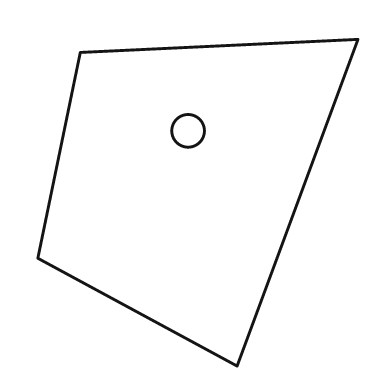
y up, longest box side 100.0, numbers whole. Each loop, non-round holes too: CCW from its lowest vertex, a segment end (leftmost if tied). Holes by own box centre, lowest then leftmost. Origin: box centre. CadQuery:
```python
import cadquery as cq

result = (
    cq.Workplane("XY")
    .moveTo(12.0, -50.0)
    .lineTo(49.0, 50.0)
    .lineTo(-36.0, 46.0)
    .lineTo(-49.0, -17.0)
    .close()
    .moveTo(-3.0, 22.0)
    .circle(5.0)
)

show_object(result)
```